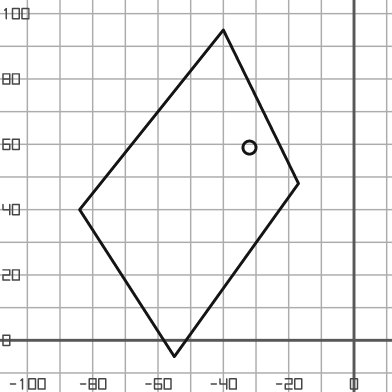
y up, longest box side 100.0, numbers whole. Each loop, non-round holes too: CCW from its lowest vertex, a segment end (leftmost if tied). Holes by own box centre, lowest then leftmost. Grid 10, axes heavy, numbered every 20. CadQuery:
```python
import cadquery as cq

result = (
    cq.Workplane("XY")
    .moveTo(-55.0, -5.0)
    .lineTo(-17.0, 48.0)
    .lineTo(-40.0, 95.0)
    .lineTo(-84.0, 40.0)
    .close()
    .moveTo(-32.0, 59.0)
    .circle(2.0)
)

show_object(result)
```